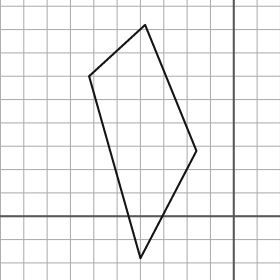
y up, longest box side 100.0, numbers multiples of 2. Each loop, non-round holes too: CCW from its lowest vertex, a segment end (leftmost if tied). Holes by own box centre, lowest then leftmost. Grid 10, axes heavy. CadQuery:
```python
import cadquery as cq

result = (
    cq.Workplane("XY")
    .moveTo(-40.0, -18.0)
    .lineTo(-16.0, 28.0)
    .lineTo(-38.0, 82.0)
    .lineTo(-62.0, 60.0)
    .close()
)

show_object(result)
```